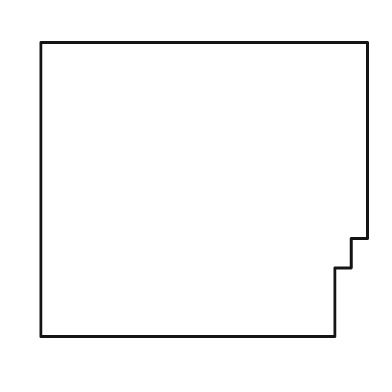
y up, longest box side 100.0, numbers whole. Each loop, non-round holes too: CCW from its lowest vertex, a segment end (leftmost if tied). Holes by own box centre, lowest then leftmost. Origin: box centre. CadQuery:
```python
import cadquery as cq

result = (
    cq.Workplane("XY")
    .moveTo(-50.0, -45.0)
    .lineTo(40.0, -45.0)
    .lineTo(40.0, -24.0)
    .lineTo(45.0, -24.0)
    .lineTo(45.0, -15.0)
    .lineTo(50.0, -15.0)
    .lineTo(50.0, 45.0)
    .lineTo(-50.0, 45.0)
    .close()
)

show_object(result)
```